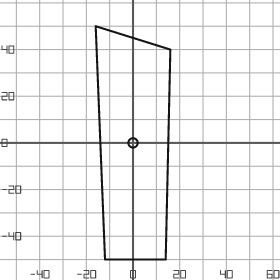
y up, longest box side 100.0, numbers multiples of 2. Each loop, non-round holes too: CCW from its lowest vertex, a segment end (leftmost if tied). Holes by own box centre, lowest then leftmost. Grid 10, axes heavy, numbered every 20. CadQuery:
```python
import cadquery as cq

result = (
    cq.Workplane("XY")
    .moveTo(-12.0, -50.0)
    .lineTo(14.0, -50.0)
    .lineTo(16.0, 40.0)
    .lineTo(-16.0, 50.0)
    .close()
    .moveTo(0.0, 0.0)
    .circle(2.0)
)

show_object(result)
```